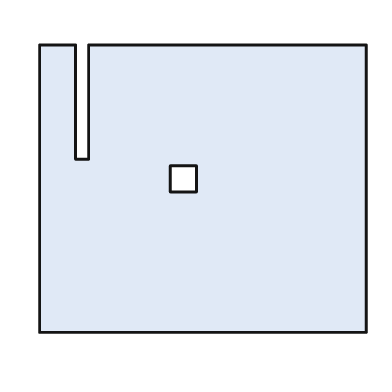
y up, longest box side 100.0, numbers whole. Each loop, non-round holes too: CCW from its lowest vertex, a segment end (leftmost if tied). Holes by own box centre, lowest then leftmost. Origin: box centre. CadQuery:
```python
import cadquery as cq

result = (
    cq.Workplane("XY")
    .moveTo(-50.0, -44.0)
    .lineTo(50.0, -44.0)
    .lineTo(50.0, 44.0)
    .lineTo(-35.0, 44.0)
    .lineTo(-35.0, 9.0)
    .lineTo(-39.0, 9.0)
    .lineTo(-39.0, 44.0)
    .lineTo(-50.0, 44.0)
    .close()
    .moveTo(-10.0, -1.0)
    .lineTo(-2.0, -1.0)
    .lineTo(-2.0, 7.0)
    .lineTo(-10.0, 7.0)
    .close()
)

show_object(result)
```